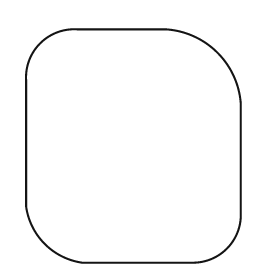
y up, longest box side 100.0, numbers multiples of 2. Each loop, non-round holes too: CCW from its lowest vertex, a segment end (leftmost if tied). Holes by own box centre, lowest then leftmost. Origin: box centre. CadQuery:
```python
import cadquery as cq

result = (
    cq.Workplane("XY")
    .moveTo(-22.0, -50.0)
    .lineTo(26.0, -50.0)
    .threePointArc((40.0, -44.0), (46.0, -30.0))
    .lineTo(46.0, 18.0)
    .threePointArc((36.0, 40.0), (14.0, 50.0))
    .lineTo(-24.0, 50.0)
    .threePointArc((-40.0, 44.0), (-46.0, 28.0))
    .lineTo(-46.0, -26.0)
    .threePointArc((-38.0, -42.0), (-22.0, -50.0))
    .close()
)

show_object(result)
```